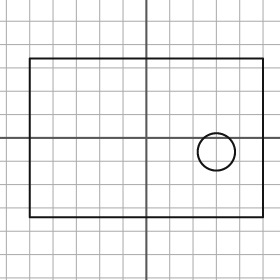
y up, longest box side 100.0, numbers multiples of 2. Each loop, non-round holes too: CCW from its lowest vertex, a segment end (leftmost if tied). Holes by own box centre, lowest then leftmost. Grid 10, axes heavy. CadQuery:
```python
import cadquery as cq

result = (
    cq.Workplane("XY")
    .moveTo(-50.0, -34.0)
    .lineTo(50.0, -34.0)
    .lineTo(50.0, 34.0)
    .lineTo(-50.0, 34.0)
    .close()
    .moveTo(30.0, -6.0)
    .circle(8.0)
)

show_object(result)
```